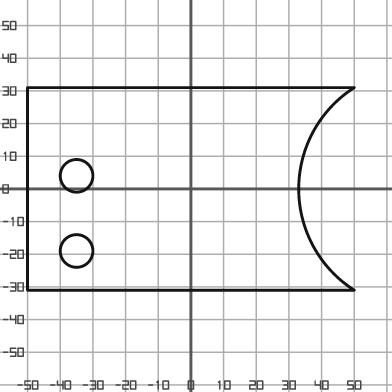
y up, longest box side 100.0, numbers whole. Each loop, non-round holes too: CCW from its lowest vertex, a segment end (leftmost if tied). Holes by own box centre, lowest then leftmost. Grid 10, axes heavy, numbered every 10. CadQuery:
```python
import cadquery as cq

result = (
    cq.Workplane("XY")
    .moveTo(-50.0, -31.0)
    .lineTo(50.0, -31.0)
    .threePointArc((33.0, 0.0), (50.0, 31.0))
    .lineTo(-50.0, 31.0)
    .close()
    .moveTo(-35.0, -19.0)
    .circle(5.0)
    .moveTo(-35.0, 4.0)
    .circle(5.0)
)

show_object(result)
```